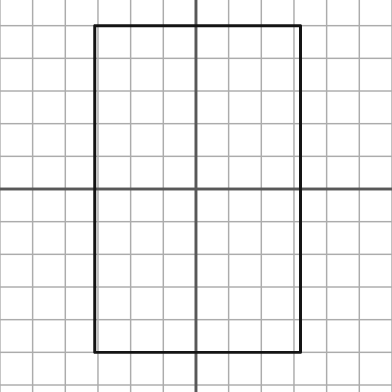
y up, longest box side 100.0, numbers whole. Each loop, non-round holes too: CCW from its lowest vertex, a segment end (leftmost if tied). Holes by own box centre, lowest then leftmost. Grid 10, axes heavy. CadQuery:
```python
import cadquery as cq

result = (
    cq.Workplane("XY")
    .moveTo(-31.0, -50.0)
    .lineTo(32.0, -50.0)
    .lineTo(32.0, 50.0)
    .lineTo(-31.0, 50.0)
    .close()
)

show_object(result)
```